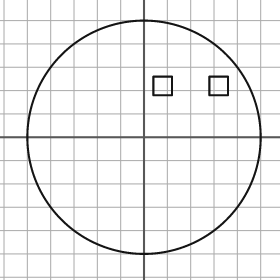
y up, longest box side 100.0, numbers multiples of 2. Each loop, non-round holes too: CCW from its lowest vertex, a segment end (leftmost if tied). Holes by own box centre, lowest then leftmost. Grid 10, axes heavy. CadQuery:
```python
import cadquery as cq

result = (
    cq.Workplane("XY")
    .moveTo(0.0, 0.0)
    .circle(50.0)
    .moveTo(4.0, 18.0)
    .lineTo(12.0, 18.0)
    .lineTo(12.0, 26.0)
    .lineTo(4.0, 26.0)
    .close()
    .moveTo(28.0, 18.0)
    .lineTo(36.0, 18.0)
    .lineTo(36.0, 26.0)
    .lineTo(28.0, 26.0)
    .close()
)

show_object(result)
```